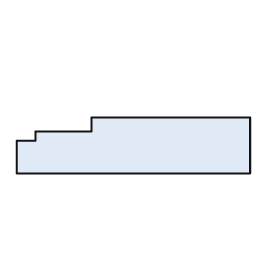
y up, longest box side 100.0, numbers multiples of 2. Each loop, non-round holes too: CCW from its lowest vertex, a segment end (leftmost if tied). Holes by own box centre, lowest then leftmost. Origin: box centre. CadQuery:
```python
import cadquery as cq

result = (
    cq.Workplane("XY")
    .moveTo(-50.0, -12.0)
    .lineTo(50.0, -12.0)
    .lineTo(50.0, 12.0)
    .lineTo(-18.0, 12.0)
    .lineTo(-18.0, 6.0)
    .lineTo(-42.0, 6.0)
    .lineTo(-42.0, 2.0)
    .lineTo(-50.0, 2.0)
    .close()
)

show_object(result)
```